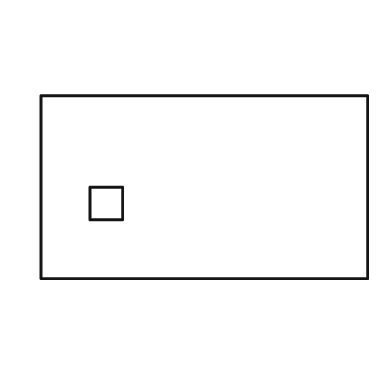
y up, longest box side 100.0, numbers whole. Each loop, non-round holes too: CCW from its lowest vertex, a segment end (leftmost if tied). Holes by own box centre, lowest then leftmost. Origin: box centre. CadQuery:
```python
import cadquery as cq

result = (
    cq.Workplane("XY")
    .moveTo(-50.0, -28.0)
    .lineTo(50.0, -28.0)
    .lineTo(50.0, 28.0)
    .lineTo(-50.0, 28.0)
    .close()
    .moveTo(-35.0, -10.0)
    .lineTo(-25.0, -10.0)
    .lineTo(-25.0, 0.0)
    .lineTo(-35.0, 0.0)
    .close()
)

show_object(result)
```